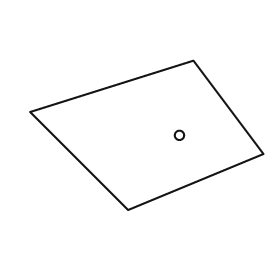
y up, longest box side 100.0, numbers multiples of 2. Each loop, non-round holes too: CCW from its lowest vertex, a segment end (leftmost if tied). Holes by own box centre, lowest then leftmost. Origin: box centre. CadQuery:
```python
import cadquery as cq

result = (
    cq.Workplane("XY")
    .moveTo(-8.0, -32.0)
    .lineTo(50.0, -8.0)
    .lineTo(20.0, 32.0)
    .lineTo(-50.0, 10.0)
    .close()
    .moveTo(14.0, 0.0)
    .circle(2.0)
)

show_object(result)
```